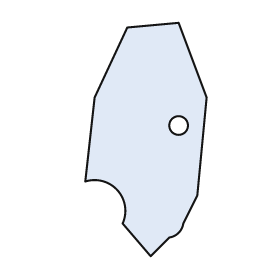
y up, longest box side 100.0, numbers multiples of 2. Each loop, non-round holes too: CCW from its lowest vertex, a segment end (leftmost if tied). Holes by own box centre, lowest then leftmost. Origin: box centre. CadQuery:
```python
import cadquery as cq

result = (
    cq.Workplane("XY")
    .moveTo(2.0, -50.0)
    .lineTo(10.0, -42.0)
    .threePointArc((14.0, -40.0), (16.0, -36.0))
    .lineTo(22.0, -24.0)
    .lineTo(26.0, 18.0)
    .lineTo(14.0, 50.0)
    .lineTo(-8.0, 48.0)
    .lineTo(-22.0, 18.0)
    .lineTo(-26.0, -18.0)
    .threePointArc((-12.0, -22.0), (-10.0, -36.0))
    .close()
    .moveTo(14.0, 6.0)
    .circle(4.0)
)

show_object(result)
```